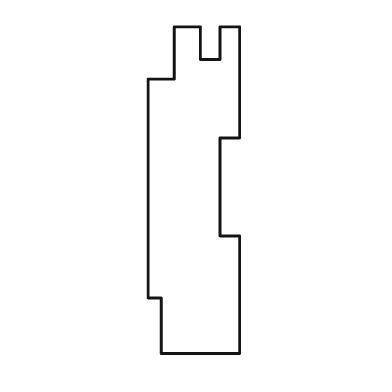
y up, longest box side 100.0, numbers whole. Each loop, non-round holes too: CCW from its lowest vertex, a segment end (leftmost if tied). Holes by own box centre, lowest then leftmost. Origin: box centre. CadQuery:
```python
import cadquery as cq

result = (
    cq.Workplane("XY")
    .moveTo(-10.0, -50.0)
    .lineTo(14.0, -50.0)
    .lineTo(14.0, -14.0)
    .lineTo(8.0, -14.0)
    .lineTo(8.0, 16.0)
    .lineTo(14.0, 16.0)
    .lineTo(14.0, 50.0)
    .lineTo(8.0, 50.0)
    .lineTo(8.0, 40.0)
    .lineTo(2.0, 40.0)
    .lineTo(2.0, 50.0)
    .lineTo(-6.0, 50.0)
    .lineTo(-6.0, 34.0)
    .lineTo(-14.0, 34.0)
    .lineTo(-14.0, -33.0)
    .lineTo(-10.0, -33.0)
    .close()
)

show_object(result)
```